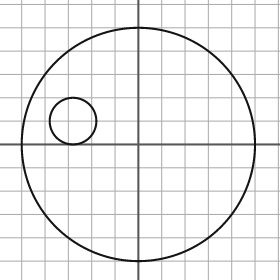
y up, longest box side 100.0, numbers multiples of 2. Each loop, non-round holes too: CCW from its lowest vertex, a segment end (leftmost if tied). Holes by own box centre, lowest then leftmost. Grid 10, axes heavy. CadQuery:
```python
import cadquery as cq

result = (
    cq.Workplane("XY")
    .moveTo(0.0, 0.0)
    .circle(50.0)
    .moveTo(-28.0, 10.0)
    .circle(10.0)
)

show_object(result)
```